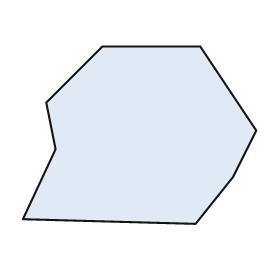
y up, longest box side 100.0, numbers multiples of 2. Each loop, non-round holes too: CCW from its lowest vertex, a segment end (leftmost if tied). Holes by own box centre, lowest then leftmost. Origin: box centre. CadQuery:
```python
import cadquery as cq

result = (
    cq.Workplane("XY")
    .moveTo(24.0, -38.0)
    .lineTo(40.0, -18.0)
    .lineTo(50.0, 2.0)
    .lineTo(26.0, 38.0)
    .lineTo(-16.0, 38.0)
    .lineTo(-40.0, 14.0)
    .lineTo(-36.0, -6.0)
    .lineTo(-50.0, -36.0)
    .close()
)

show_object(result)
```